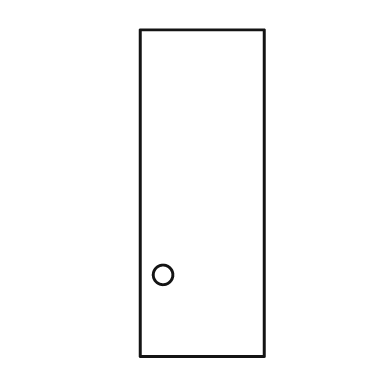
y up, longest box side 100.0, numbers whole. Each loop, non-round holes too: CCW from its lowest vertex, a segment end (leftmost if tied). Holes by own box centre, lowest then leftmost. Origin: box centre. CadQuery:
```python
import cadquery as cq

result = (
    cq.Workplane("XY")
    .moveTo(-19.0, -50.0)
    .lineTo(19.0, -50.0)
    .lineTo(19.0, 50.0)
    .lineTo(-19.0, 50.0)
    .close()
    .moveTo(-12.0, -25.0)
    .circle(3.0)
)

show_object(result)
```